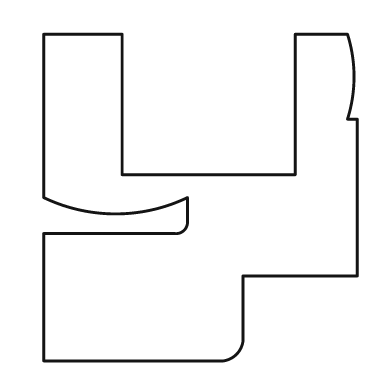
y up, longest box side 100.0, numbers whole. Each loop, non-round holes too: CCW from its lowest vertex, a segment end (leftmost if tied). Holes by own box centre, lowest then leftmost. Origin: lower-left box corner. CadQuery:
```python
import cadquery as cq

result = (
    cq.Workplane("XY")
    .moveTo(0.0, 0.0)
    .lineTo(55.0, 0.0)
    .threePointArc((59.0, 2.0), (61.0, 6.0))
    .lineTo(61.0, 26.0)
    .lineTo(96.0, 26.0)
    .lineTo(96.0, 74.0)
    .lineTo(93.0, 74.0)
    .threePointArc((95.0, 87.0), (93.0, 100.0))
    .lineTo(77.0, 100.0)
    .lineTo(77.0, 57.0)
    .lineTo(24.0, 57.0)
    .lineTo(24.0, 100.0)
    .lineTo(0.0, 100.0)
    .lineTo(0.0, 50.0)
    .threePointArc((22.0, 45.0), (44.0, 50.0))
    .lineTo(44.0, 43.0)
    .threePointArc((43.0, 40.0), (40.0, 39.0))
    .lineTo(0.0, 39.0)
    .close()
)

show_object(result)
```